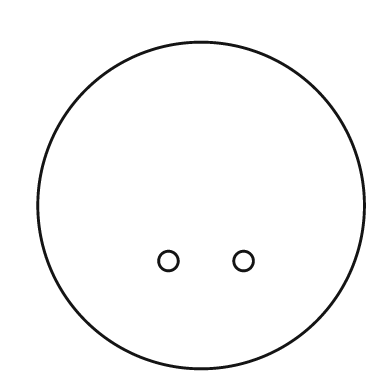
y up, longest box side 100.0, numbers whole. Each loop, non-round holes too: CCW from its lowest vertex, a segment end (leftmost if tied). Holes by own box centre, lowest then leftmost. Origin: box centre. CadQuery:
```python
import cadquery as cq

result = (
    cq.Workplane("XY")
    .moveTo(0.0, 0.0)
    .circle(50.0)
    .moveTo(-10.0, -17.0)
    .circle(3.0)
    .moveTo(13.0, -17.0)
    .circle(3.0)
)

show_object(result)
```